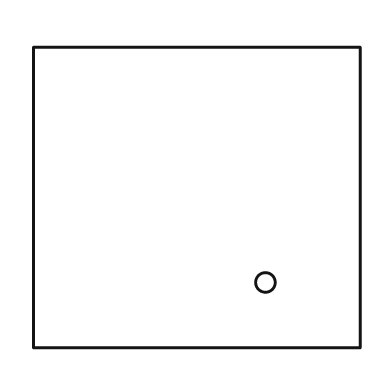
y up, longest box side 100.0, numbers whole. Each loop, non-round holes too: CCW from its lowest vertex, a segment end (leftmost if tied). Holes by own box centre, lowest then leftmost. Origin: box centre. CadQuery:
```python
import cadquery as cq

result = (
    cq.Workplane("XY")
    .moveTo(-50.0, -46.0)
    .lineTo(50.0, -46.0)
    .lineTo(50.0, 46.0)
    .lineTo(-50.0, 46.0)
    .close()
    .moveTo(21.0, -26.0)
    .circle(3.0)
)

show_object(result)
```